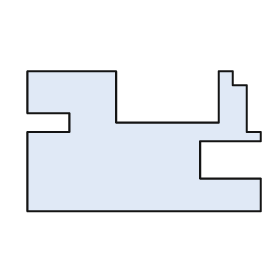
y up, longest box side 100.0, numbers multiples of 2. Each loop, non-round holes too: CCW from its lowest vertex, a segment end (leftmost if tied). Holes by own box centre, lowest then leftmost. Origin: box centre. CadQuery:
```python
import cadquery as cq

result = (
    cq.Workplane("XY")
    .moveTo(-50.0, -30.0)
    .lineTo(50.0, -30.0)
    .lineTo(50.0, -16.0)
    .lineTo(24.0, -16.0)
    .lineTo(24.0, 0.0)
    .lineTo(50.0, 0.0)
    .lineTo(50.0, 4.0)
    .lineTo(44.0, 4.0)
    .lineTo(44.0, 24.0)
    .lineTo(38.0, 24.0)
    .lineTo(38.0, 30.0)
    .lineTo(32.0, 30.0)
    .lineTo(32.0, 8.0)
    .lineTo(-12.0, 8.0)
    .lineTo(-12.0, 30.0)
    .lineTo(-50.0, 30.0)
    .lineTo(-50.0, 12.0)
    .lineTo(-32.0, 12.0)
    .lineTo(-32.0, 4.0)
    .lineTo(-50.0, 4.0)
    .close()
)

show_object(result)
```